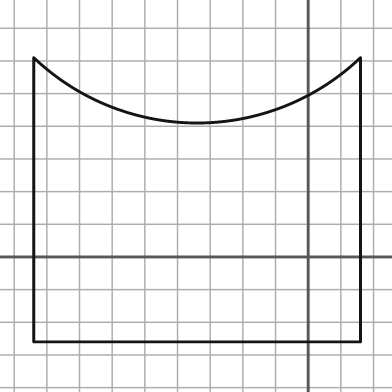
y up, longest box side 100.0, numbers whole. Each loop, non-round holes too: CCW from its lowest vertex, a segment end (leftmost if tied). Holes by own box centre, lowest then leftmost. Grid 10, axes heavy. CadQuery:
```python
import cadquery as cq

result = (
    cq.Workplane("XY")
    .moveTo(-84.0, -26.0)
    .lineTo(16.0, -26.0)
    .lineTo(16.0, 61.0)
    .threePointArc((-34.0, 41.0), (-84.0, 61.0))
    .close()
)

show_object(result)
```